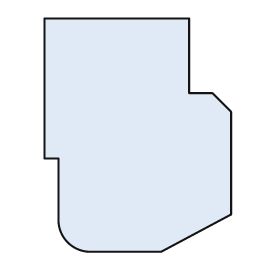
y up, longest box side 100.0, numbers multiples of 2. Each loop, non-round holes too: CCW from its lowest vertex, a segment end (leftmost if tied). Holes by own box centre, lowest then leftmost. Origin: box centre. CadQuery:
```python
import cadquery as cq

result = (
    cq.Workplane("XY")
    .moveTo(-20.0, -50.0)
    .lineTo(10.0, -50.0)
    .lineTo(40.0, -34.0)
    .lineTo(40.0, 10.0)
    .lineTo(32.0, 18.0)
    .lineTo(22.0, 18.0)
    .lineTo(22.0, 50.0)
    .lineTo(-40.0, 50.0)
    .lineTo(-40.0, -10.0)
    .lineTo(-34.0, -10.0)
    .lineTo(-34.0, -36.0)
    .threePointArc((-30.0, -46.0), (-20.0, -50.0))
    .close()
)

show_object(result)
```